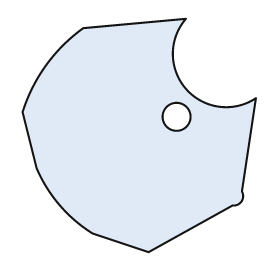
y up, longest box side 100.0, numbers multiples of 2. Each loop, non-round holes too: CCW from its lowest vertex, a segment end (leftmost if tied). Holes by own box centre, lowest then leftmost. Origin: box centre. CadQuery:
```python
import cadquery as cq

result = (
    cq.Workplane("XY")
    .moveTo(4.0, -50.0)
    .lineTo(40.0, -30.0)
    .threePointArc((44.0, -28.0), (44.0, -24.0))
    .lineTo(50.0, 16.0)
    .threePointArc((20.0, 20.0), (20.0, 50.0))
    .lineTo(-24.0, 46.0)
    .threePointArc((-40.0, 30.0), (-50.0, 10.0))
    .lineTo(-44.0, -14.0)
    .threePointArc((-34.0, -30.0), (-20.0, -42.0))
    .close()
    .moveTo(16.0, 8.0)
    .circle(6.0)
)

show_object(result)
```